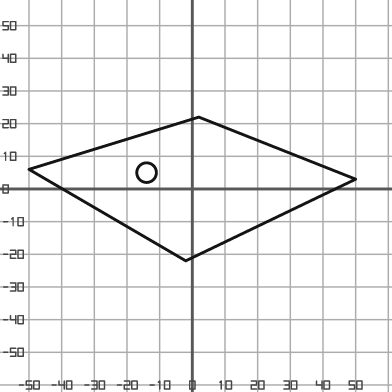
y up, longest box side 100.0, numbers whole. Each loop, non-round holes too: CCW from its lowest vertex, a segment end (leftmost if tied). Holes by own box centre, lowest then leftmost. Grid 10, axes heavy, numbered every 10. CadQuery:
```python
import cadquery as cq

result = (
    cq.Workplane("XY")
    .moveTo(-2.0, -22.0)
    .lineTo(50.0, 3.0)
    .lineTo(2.0, 22.0)
    .lineTo(-50.0, 6.0)
    .close()
    .moveTo(-14.0, 5.0)
    .circle(3.0)
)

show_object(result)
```